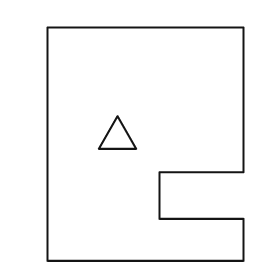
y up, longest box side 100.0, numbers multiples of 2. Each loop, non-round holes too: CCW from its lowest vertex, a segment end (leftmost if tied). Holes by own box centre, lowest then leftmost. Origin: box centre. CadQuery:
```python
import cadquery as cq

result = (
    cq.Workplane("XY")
    .moveTo(-42.0, -50.0)
    .lineTo(42.0, -50.0)
    .lineTo(42.0, -32.0)
    .lineTo(6.0, -32.0)
    .lineTo(6.0, -12.0)
    .lineTo(42.0, -12.0)
    .lineTo(42.0, 50.0)
    .lineTo(-42.0, 50.0)
    .close()
    .moveTo(-20.0, -2.0)
    .lineTo(-4.0, -2.0)
    .lineTo(-12.0, 12.0)
    .close()
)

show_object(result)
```